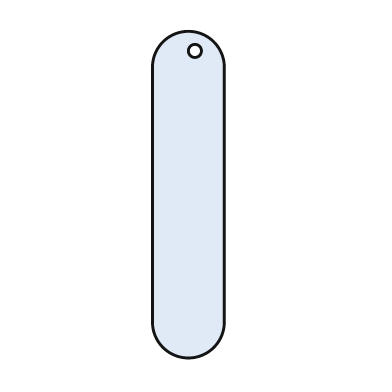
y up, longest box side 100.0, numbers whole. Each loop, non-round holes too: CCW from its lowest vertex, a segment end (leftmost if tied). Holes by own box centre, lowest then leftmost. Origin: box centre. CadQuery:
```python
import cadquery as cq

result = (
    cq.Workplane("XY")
    .moveTo(-11.0, -39.0)
    .threePointArc((0.0, -50.0), (11.0, -39.0))
    .lineTo(11.0, 39.0)
    .threePointArc((0.0, 50.0), (-11.0, 39.0))
    .close()
    .moveTo(2.0, 44.0)
    .circle(2.0)
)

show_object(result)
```